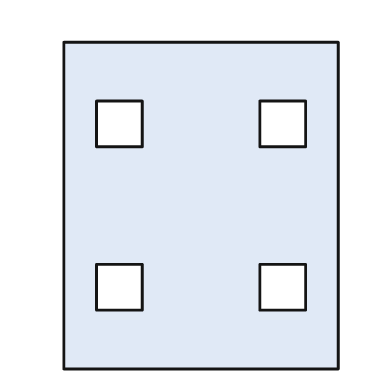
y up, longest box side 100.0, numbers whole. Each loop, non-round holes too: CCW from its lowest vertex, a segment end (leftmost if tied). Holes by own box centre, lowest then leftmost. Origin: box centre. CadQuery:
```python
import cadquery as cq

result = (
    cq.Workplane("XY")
    .moveTo(-42.0, -50.0)
    .lineTo(42.0, -50.0)
    .lineTo(42.0, 50.0)
    .lineTo(-42.0, 50.0)
    .close()
    .moveTo(-32.0, -32.0)
    .lineTo(-18.0, -32.0)
    .lineTo(-18.0, -18.0)
    .lineTo(-32.0, -18.0)
    .close()
    .moveTo(18.0, -32.0)
    .lineTo(32.0, -32.0)
    .lineTo(32.0, -18.0)
    .lineTo(18.0, -18.0)
    .close()
    .moveTo(-32.0, 18.0)
    .lineTo(-18.0, 18.0)
    .lineTo(-18.0, 32.0)
    .lineTo(-32.0, 32.0)
    .close()
    .moveTo(18.0, 18.0)
    .lineTo(32.0, 18.0)
    .lineTo(32.0, 32.0)
    .lineTo(18.0, 32.0)
    .close()
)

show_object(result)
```